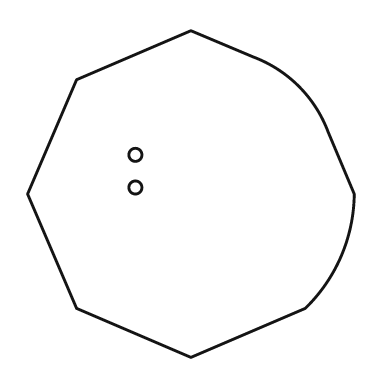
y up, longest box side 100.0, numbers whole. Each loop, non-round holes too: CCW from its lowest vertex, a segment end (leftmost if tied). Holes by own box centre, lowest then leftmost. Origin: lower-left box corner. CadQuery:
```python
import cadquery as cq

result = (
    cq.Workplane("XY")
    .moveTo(50.0, 0.0)
    .lineTo(85.0, 15.0)
    .threePointArc((96.0, 31.0), (100.0, 50.0))
    .lineTo(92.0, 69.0)
    .threePointArc((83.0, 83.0), (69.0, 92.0))
    .lineTo(50.0, 100.0)
    .lineTo(15.0, 85.0)
    .lineTo(0.0, 50.0)
    .lineTo(15.0, 15.0)
    .close()
    .moveTo(33.0, 52.0)
    .circle(2.0)
    .moveTo(33.0, 62.0)
    .circle(2.0)
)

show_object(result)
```